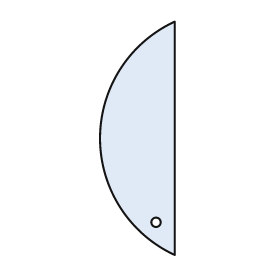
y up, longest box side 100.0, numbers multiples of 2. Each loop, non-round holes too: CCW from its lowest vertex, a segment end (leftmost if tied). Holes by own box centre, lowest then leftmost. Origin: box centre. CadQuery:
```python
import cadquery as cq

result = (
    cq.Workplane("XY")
    .moveTo(16.0, -50.0)
    .lineTo(16.0, 50.0)
    .threePointArc((-16.0, 0.0), (16.0, -50.0))
    .close()
    .moveTo(8.0, -36.0)
    .circle(2.0)
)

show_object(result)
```